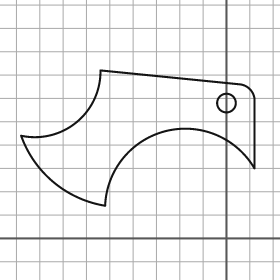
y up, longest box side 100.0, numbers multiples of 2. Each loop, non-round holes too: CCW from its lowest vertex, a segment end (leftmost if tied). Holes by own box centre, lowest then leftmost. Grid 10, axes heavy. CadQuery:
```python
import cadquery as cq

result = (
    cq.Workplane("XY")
    .moveTo(-52.0, 14.0)
    .threePointArc((-26.0, 46.0), (12.0, 30.0))
    .lineTo(12.0, 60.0)
    .threePointArc((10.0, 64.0), (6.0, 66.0))
    .lineTo(-54.0, 72.0)
    .threePointArc((-64.0, 50.0), (-88.0, 44.0))
    .threePointArc((-74.0, 24.0), (-52.0, 14.0))
    .close()
    .moveTo(0.0, 58.0)
    .circle(4.0)
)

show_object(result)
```